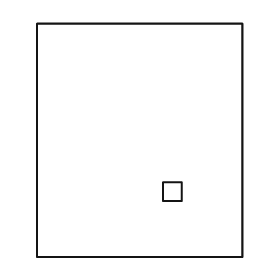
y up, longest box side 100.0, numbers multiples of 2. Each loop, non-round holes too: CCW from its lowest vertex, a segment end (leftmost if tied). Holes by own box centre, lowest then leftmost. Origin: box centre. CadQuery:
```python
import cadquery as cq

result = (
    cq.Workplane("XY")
    .moveTo(-44.0, -50.0)
    .lineTo(44.0, -50.0)
    .lineTo(44.0, 50.0)
    .lineTo(-44.0, 50.0)
    .close()
    .moveTo(10.0, -26.0)
    .lineTo(18.0, -26.0)
    .lineTo(18.0, -18.0)
    .lineTo(10.0, -18.0)
    .close()
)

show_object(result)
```